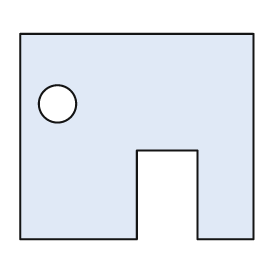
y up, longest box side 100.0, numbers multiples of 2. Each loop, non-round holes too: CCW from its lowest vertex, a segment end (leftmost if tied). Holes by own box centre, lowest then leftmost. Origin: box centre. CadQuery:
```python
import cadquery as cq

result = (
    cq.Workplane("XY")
    .moveTo(-50.0, -44.0)
    .lineTo(0.0, -44.0)
    .lineTo(0.0, -6.0)
    .lineTo(26.0, -6.0)
    .lineTo(26.0, -44.0)
    .lineTo(50.0, -44.0)
    .lineTo(50.0, 44.0)
    .lineTo(-50.0, 44.0)
    .close()
    .moveTo(-34.0, 14.0)
    .circle(8.0)
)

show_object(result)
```